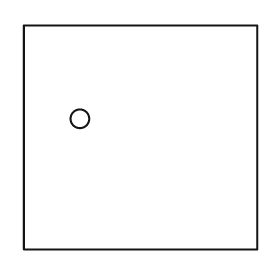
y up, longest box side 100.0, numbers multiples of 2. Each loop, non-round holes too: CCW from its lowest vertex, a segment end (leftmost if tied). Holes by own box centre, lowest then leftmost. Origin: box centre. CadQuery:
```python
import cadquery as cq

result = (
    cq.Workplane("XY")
    .moveTo(-50.0, -48.0)
    .lineTo(50.0, -48.0)
    .lineTo(50.0, 48.0)
    .lineTo(-50.0, 48.0)
    .close()
    .moveTo(-26.0, 8.0)
    .circle(4.0)
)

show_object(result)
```